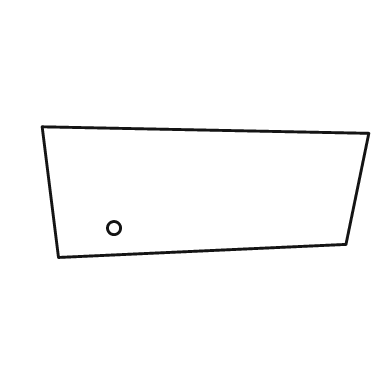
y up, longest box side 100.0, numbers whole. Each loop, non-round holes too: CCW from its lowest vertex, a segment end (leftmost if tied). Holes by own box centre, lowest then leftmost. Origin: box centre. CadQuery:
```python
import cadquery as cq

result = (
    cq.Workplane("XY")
    .moveTo(-45.0, -20.0)
    .lineTo(43.0, -16.0)
    .lineTo(50.0, 18.0)
    .lineTo(-50.0, 20.0)
    .close()
    .moveTo(-28.0, -11.0)
    .circle(2.0)
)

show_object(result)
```